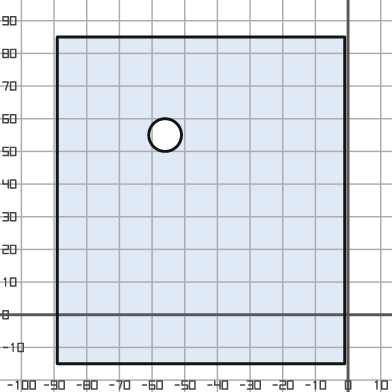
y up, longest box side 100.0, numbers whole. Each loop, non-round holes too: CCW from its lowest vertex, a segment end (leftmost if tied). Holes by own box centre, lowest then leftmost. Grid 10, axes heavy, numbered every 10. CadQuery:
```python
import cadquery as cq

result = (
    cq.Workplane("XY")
    .moveTo(-89.0, -15.0)
    .lineTo(-1.0, -15.0)
    .lineTo(-1.0, 85.0)
    .lineTo(-89.0, 85.0)
    .close()
    .moveTo(-56.0, 55.0)
    .circle(5.0)
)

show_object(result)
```